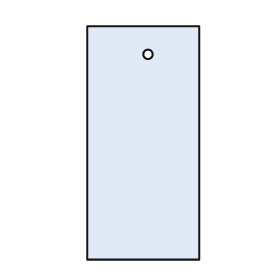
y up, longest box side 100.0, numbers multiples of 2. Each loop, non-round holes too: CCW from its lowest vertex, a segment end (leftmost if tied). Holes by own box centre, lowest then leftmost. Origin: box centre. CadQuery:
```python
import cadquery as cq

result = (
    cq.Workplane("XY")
    .moveTo(-24.0, -50.0)
    .lineTo(24.0, -50.0)
    .lineTo(24.0, 50.0)
    .lineTo(-24.0, 50.0)
    .close()
    .moveTo(2.0, 38.0)
    .circle(2.0)
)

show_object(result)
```